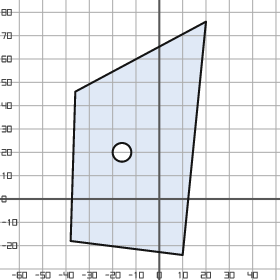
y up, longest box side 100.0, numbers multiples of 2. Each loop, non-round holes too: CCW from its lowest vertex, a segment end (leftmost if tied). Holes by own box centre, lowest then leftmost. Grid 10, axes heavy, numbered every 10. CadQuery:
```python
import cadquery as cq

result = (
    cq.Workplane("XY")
    .moveTo(10.0, -24.0)
    .lineTo(20.0, 76.0)
    .lineTo(-36.0, 46.0)
    .lineTo(-38.0, -18.0)
    .close()
    .moveTo(-16.0, 20.0)
    .circle(4.0)
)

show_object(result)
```